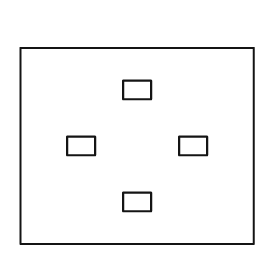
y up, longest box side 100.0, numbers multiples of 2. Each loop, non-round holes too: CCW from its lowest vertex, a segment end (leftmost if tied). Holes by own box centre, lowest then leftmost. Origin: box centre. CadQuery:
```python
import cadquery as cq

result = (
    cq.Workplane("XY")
    .moveTo(-50.0, -42.0)
    .lineTo(50.0, -42.0)
    .lineTo(50.0, 42.0)
    .lineTo(-50.0, 42.0)
    .close()
    .moveTo(-6.0, -28.0)
    .lineTo(6.0, -28.0)
    .lineTo(6.0, -20.0)
    .lineTo(-6.0, -20.0)
    .close()
    .moveTo(-30.0, -4.0)
    .lineTo(-18.0, -4.0)
    .lineTo(-18.0, 4.0)
    .lineTo(-30.0, 4.0)
    .close()
    .moveTo(18.0, -4.0)
    .lineTo(30.0, -4.0)
    .lineTo(30.0, 4.0)
    .lineTo(18.0, 4.0)
    .close()
    .moveTo(-6.0, 20.0)
    .lineTo(6.0, 20.0)
    .lineTo(6.0, 28.0)
    .lineTo(-6.0, 28.0)
    .close()
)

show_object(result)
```